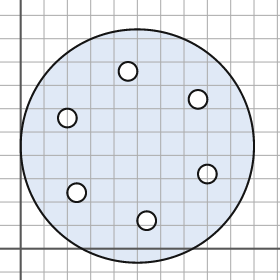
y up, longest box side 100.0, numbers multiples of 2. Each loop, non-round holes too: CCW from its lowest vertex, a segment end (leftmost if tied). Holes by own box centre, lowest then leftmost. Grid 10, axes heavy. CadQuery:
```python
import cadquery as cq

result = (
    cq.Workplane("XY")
    .moveTo(50.0, 44.0)
    .circle(50.0)
    .moveTo(54.0, 12.0)
    .circle(4.0)
    .moveTo(24.0, 24.0)
    .circle(4.0)
    .moveTo(80.0, 32.0)
    .circle(4.0)
    .moveTo(20.0, 56.0)
    .circle(4.0)
    .moveTo(76.0, 64.0)
    .circle(4.0)
    .moveTo(46.0, 76.0)
    .circle(4.0)
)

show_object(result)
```